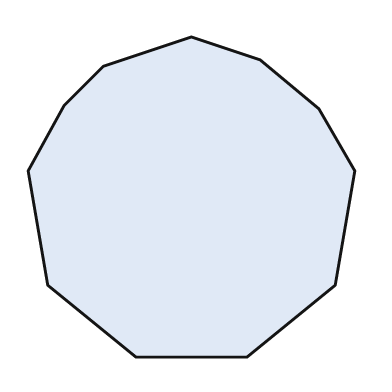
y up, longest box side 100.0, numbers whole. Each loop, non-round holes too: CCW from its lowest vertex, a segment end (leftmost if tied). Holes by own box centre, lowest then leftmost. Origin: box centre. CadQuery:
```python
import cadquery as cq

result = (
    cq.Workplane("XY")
    .moveTo(-17.0, -49.0)
    .lineTo(17.0, -49.0)
    .lineTo(44.0, -27.0)
    .lineTo(50.0, 8.0)
    .lineTo(39.0, 27.0)
    .lineTo(21.0, 42.0)
    .lineTo(0.0, 49.0)
    .lineTo(-27.0, 40.0)
    .lineTo(-39.0, 28.0)
    .lineTo(-50.0, 8.0)
    .lineTo(-44.0, -27.0)
    .close()
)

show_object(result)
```